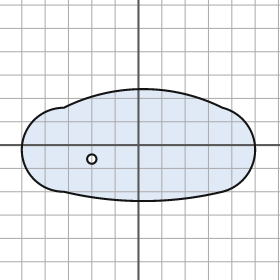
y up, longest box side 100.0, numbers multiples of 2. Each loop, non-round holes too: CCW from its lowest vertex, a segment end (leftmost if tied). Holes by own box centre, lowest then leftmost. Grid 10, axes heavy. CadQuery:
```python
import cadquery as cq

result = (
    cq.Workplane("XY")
    .moveTo(-32.0, -20.0)
    .threePointArc((2.0, -24.0), (36.0, -20.0))
    .threePointArc((50.0, -2.0), (36.0, 16.0))
    .threePointArc((2.0, 24.0), (-32.0, 16.0))
    .threePointArc((-50.0, -2.0), (-32.0, -20.0))
    .close()
    .moveTo(-20.0, -6.0)
    .circle(2.0)
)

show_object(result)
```